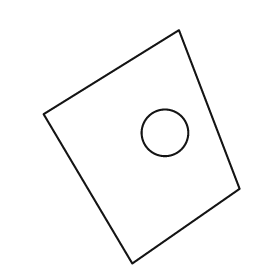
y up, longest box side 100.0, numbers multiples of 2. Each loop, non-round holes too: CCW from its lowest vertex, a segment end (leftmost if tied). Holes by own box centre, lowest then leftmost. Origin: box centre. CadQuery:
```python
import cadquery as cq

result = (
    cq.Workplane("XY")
    .moveTo(-4.0, -50.0)
    .lineTo(42.0, -18.0)
    .lineTo(16.0, 50.0)
    .lineTo(-42.0, 14.0)
    .close()
    .moveTo(10.0, 6.0)
    .circle(10.0)
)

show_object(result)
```